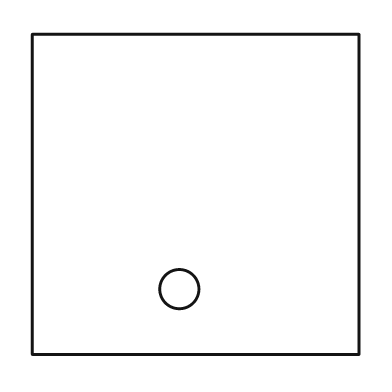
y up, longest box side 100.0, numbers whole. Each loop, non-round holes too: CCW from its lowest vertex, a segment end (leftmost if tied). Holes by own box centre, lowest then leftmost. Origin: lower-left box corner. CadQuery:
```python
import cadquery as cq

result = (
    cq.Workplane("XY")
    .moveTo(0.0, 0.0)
    .lineTo(100.0, 0.0)
    .lineTo(100.0, 98.0)
    .lineTo(0.0, 98.0)
    .close()
    .moveTo(45.0, 20.0)
    .circle(6.0)
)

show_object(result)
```